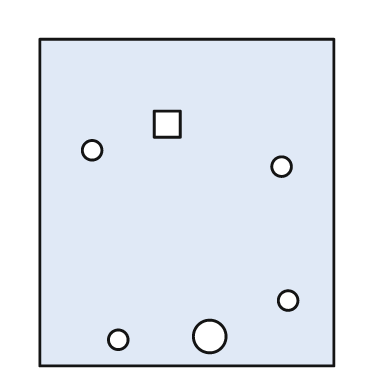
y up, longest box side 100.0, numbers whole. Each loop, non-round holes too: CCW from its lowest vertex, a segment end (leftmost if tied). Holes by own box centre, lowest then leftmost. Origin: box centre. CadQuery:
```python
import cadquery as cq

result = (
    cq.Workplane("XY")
    .moveTo(-45.0, -50.0)
    .lineTo(45.0, -50.0)
    .lineTo(45.0, 50.0)
    .lineTo(-45.0, 50.0)
    .close()
    .moveTo(-21.0, -42.0)
    .circle(3.0)
    .moveTo(7.0, -41.0)
    .circle(5.0)
    .moveTo(31.0, -30.0)
    .circle(3.0)
    .moveTo(29.0, 11.0)
    .circle(3.0)
    .moveTo(-29.0, 16.0)
    .circle(3.0)
    .moveTo(-10.0, 20.0)
    .lineTo(-2.0, 20.0)
    .lineTo(-2.0, 28.0)
    .lineTo(-10.0, 28.0)
    .close()
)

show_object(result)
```